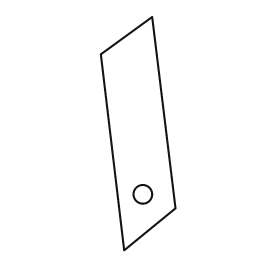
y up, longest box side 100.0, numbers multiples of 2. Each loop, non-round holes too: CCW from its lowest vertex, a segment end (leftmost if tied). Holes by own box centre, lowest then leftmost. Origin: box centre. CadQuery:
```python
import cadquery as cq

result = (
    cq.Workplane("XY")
    .moveTo(-6.0, -50.0)
    .lineTo(16.0, -32.0)
    .lineTo(6.0, 50.0)
    .lineTo(-16.0, 34.0)
    .close()
    .moveTo(2.0, -26.0)
    .circle(4.0)
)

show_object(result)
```